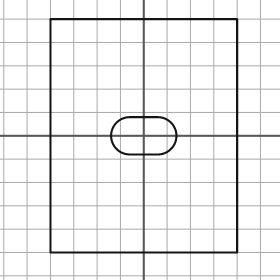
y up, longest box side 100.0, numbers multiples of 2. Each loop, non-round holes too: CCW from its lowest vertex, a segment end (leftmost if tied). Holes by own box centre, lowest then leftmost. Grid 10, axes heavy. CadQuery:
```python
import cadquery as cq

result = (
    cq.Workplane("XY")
    .moveTo(-40.0, -50.0)
    .lineTo(40.0, -50.0)
    .lineTo(40.0, 50.0)
    .lineTo(-40.0, 50.0)
    .close()
    .moveTo(-6.0, -8.0)
    .lineTo(6.0, -8.0)
    .threePointArc((14.0, 0.0), (6.0, 8.0))
    .lineTo(-6.0, 8.0)
    .threePointArc((-14.0, 0.0), (-6.0, -8.0))
    .close()
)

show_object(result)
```